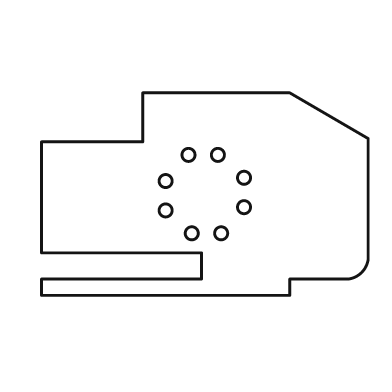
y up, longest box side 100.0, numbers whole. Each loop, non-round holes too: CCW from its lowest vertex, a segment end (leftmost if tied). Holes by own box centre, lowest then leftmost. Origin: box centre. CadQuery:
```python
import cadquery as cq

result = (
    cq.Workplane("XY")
    .moveTo(-50.0, -31.0)
    .lineTo(26.0, -31.0)
    .lineTo(26.0, -26.0)
    .lineTo(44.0, -26.0)
    .threePointArc((48.0, -24.0), (50.0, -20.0))
    .lineTo(50.0, 17.0)
    .lineTo(26.0, 31.0)
    .lineTo(-19.0, 31.0)
    .lineTo(-19.0, 16.0)
    .lineTo(-50.0, 16.0)
    .lineTo(-50.0, -18.0)
    .lineTo(-1.0, -18.0)
    .lineTo(-1.0, -26.0)
    .lineTo(-50.0, -26.0)
    .close()
    .moveTo(-4.0, -12.0)
    .circle(2.0)
    .moveTo(5.0, -12.0)
    .circle(2.0)
    .moveTo(-12.0, -5.0)
    .circle(2.0)
    .moveTo(12.0, -4.0)
    .circle(2.0)
    .moveTo(-12.0, 4.0)
    .circle(2.0)
    .moveTo(12.0, 5.0)
    .circle(2.0)
    .moveTo(-5.0, 12.0)
    .circle(2.0)
    .moveTo(4.0, 12.0)
    .circle(2.0)
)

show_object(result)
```